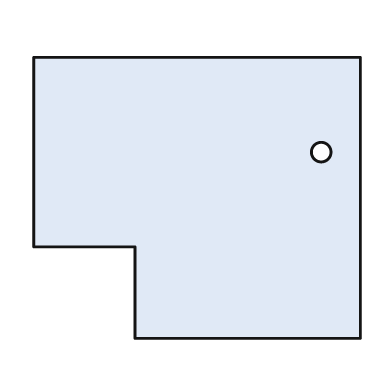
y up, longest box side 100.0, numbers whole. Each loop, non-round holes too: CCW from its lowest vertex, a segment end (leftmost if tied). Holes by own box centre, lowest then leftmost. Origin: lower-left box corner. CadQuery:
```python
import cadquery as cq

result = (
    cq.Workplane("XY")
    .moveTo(31.0, 0.0)
    .lineTo(100.0, 0.0)
    .lineTo(100.0, 86.0)
    .lineTo(0.0, 86.0)
    .lineTo(0.0, 28.0)
    .lineTo(31.0, 28.0)
    .close()
    .moveTo(88.0, 57.0)
    .circle(3.0)
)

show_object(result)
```